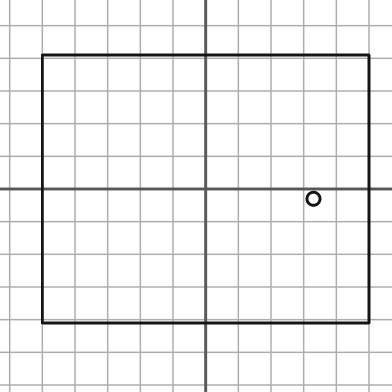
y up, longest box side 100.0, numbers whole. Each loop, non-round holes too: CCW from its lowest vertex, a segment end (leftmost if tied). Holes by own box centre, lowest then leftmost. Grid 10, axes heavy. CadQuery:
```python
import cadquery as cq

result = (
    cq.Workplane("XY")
    .moveTo(-50.0, -41.0)
    .lineTo(50.0, -41.0)
    .lineTo(50.0, 41.0)
    .lineTo(-50.0, 41.0)
    .close()
    .moveTo(33.0, -3.0)
    .circle(2.0)
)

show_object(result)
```